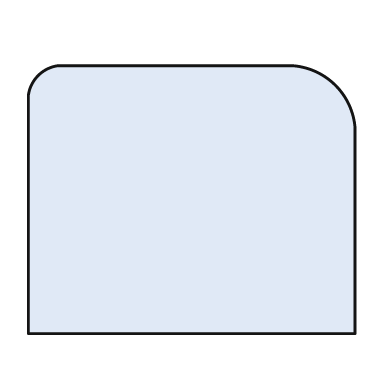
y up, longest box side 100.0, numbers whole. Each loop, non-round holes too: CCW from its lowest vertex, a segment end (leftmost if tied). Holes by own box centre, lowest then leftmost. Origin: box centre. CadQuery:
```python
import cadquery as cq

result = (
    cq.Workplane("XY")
    .moveTo(-50.0, -41.0)
    .lineTo(50.0, -41.0)
    .lineTo(50.0, 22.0)
    .threePointArc((44.0, 35.0), (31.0, 41.0))
    .lineTo(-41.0, 41.0)
    .threePointArc((-47.0, 38.0), (-50.0, 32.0))
    .close()
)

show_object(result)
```